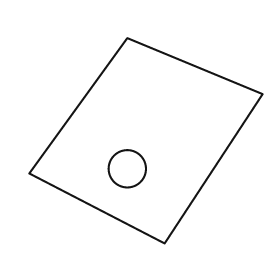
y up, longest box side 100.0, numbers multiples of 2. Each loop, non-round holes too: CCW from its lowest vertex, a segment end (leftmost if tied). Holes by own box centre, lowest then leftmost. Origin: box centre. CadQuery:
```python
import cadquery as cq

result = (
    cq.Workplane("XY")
    .moveTo(8.0, -44.0)
    .lineTo(50.0, 20.0)
    .lineTo(-8.0, 44.0)
    .lineTo(-50.0, -14.0)
    .close()
    .moveTo(-8.0, -12.0)
    .circle(8.0)
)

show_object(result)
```